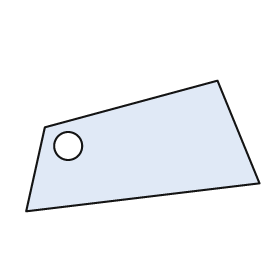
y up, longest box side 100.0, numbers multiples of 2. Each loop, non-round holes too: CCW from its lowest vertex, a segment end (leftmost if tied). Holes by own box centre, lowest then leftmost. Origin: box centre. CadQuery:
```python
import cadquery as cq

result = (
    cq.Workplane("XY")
    .moveTo(-50.0, -28.0)
    .lineTo(50.0, -16.0)
    .lineTo(32.0, 28.0)
    .lineTo(-42.0, 8.0)
    .close()
    .moveTo(-32.0, 0.0)
    .circle(6.0)
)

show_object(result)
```